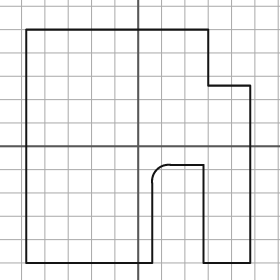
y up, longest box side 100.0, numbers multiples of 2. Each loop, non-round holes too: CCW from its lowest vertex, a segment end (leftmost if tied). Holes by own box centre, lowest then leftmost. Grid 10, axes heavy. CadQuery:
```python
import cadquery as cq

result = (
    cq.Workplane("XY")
    .moveTo(-48.0, -50.0)
    .lineTo(6.0, -50.0)
    .lineTo(6.0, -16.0)
    .threePointArc((8.0, -10.0), (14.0, -8.0))
    .lineTo(28.0, -8.0)
    .lineTo(28.0, -50.0)
    .lineTo(48.0, -50.0)
    .lineTo(48.0, 26.0)
    .lineTo(30.0, 26.0)
    .lineTo(30.0, 50.0)
    .lineTo(-48.0, 50.0)
    .close()
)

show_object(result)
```